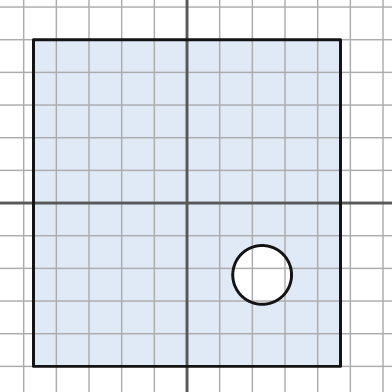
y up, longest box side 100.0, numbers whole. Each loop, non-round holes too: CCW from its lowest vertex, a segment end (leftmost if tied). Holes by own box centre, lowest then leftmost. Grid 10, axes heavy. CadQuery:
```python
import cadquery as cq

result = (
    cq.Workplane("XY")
    .moveTo(-47.0, -50.0)
    .lineTo(47.0, -50.0)
    .lineTo(47.0, 50.0)
    .lineTo(-47.0, 50.0)
    .close()
    .moveTo(23.0, -22.0)
    .circle(9.0)
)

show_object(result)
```